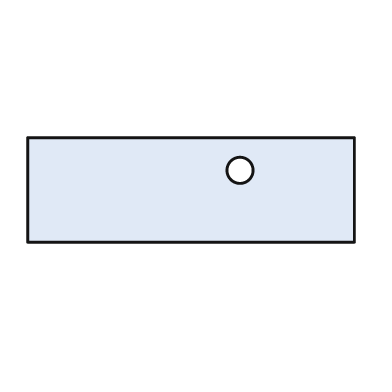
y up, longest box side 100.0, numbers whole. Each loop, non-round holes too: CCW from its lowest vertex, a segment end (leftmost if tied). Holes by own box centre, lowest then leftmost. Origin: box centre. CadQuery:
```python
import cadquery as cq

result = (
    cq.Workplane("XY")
    .moveTo(-50.0, -16.0)
    .lineTo(50.0, -16.0)
    .lineTo(50.0, 16.0)
    .lineTo(-50.0, 16.0)
    .close()
    .moveTo(15.0, 6.0)
    .circle(4.0)
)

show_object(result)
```